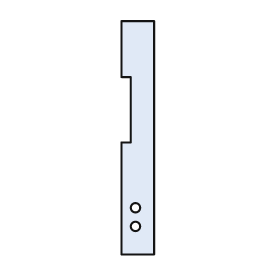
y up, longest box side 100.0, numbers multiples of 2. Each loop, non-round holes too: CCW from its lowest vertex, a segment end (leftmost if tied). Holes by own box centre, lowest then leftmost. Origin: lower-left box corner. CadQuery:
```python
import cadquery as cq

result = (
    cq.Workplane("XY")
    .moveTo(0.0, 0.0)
    .lineTo(14.0, 0.0)
    .lineTo(14.0, 100.0)
    .lineTo(0.0, 100.0)
    .lineTo(0.0, 76.0)
    .lineTo(4.0, 76.0)
    .lineTo(4.0, 48.0)
    .lineTo(0.0, 48.0)
    .close()
    .moveTo(6.0, 12.0)
    .circle(2.0)
    .moveTo(6.0, 20.0)
    .circle(2.0)
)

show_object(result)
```